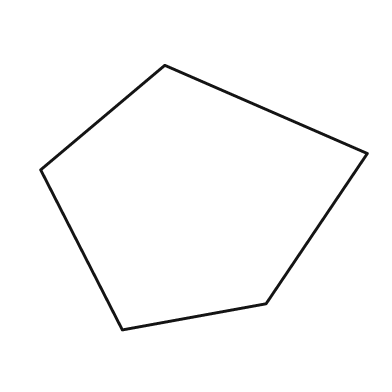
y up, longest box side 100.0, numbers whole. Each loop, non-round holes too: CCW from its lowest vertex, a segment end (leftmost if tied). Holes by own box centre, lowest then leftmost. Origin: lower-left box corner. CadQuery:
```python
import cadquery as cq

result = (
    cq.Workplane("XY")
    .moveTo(25.0, 0.0)
    .lineTo(69.0, 8.0)
    .lineTo(100.0, 54.0)
    .lineTo(38.0, 81.0)
    .lineTo(0.0, 49.0)
    .close()
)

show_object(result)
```